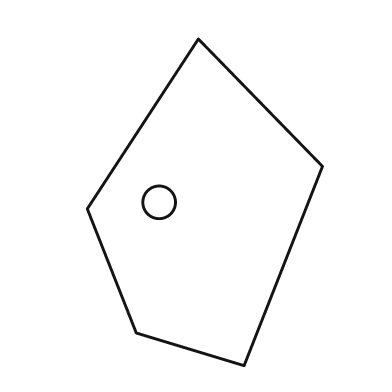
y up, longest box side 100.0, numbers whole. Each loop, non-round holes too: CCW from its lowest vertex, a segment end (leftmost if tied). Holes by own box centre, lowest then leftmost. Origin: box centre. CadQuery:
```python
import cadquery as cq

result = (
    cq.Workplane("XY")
    .moveTo(12.0, -50.0)
    .lineTo(36.0, 11.0)
    .lineTo(-2.0, 50.0)
    .lineTo(-36.0, -2.0)
    .lineTo(-21.0, -40.0)
    .close()
    .moveTo(-14.0, 0.0)
    .circle(5.0)
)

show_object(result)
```